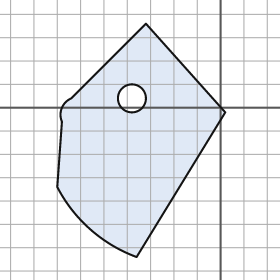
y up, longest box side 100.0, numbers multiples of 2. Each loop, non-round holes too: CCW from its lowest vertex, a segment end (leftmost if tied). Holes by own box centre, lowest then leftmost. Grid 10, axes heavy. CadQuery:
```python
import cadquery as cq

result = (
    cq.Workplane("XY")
    .moveTo(-36.0, -64.0)
    .lineTo(2.0, -2.0)
    .lineTo(-32.0, 36.0)
    .lineTo(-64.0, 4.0)
    .threePointArc((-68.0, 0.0), (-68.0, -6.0))
    .lineTo(-70.0, -34.0)
    .threePointArc((-56.0, -52.0), (-36.0, -64.0))
    .close()
    .moveTo(-38.0, 4.0)
    .circle(6.0)
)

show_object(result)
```